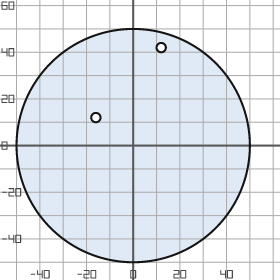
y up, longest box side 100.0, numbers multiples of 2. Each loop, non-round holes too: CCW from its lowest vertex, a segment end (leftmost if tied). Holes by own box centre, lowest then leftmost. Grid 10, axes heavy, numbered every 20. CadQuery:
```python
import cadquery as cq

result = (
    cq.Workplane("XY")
    .moveTo(0.0, 0.0)
    .circle(50.0)
    .moveTo(-16.0, 12.0)
    .circle(2.0)
    .moveTo(12.0, 42.0)
    .circle(2.0)
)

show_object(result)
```